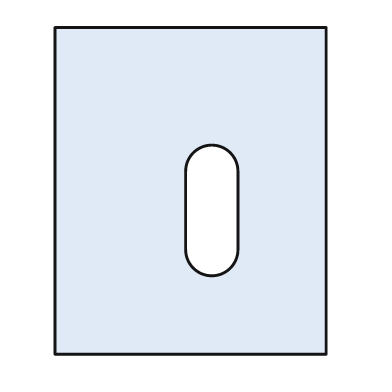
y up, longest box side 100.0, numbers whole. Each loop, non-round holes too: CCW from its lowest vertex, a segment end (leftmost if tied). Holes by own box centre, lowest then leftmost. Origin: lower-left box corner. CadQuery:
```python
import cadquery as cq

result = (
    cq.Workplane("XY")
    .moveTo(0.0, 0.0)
    .lineTo(83.0, 0.0)
    .lineTo(83.0, 100.0)
    .lineTo(0.0, 100.0)
    .close()
    .moveTo(40.0, 32.0)
    .threePointArc((48.0, 24.0), (56.0, 32.0))
    .lineTo(56.0, 56.0)
    .threePointArc((48.0, 64.0), (40.0, 56.0))
    .close()
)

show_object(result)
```